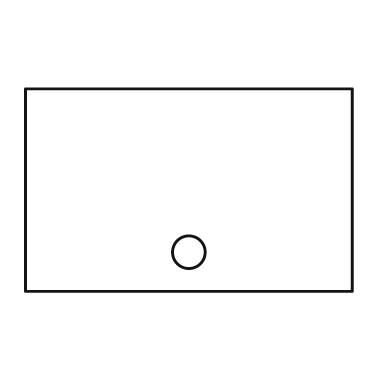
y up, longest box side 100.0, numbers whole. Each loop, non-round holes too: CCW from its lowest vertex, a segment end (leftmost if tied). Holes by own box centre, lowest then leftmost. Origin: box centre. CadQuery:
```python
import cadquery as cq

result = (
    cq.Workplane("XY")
    .moveTo(-50.0, -31.0)
    .lineTo(50.0, -31.0)
    .lineTo(50.0, 31.0)
    .lineTo(-50.0, 31.0)
    .close()
    .moveTo(0.0, -19.0)
    .circle(5.0)
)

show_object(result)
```